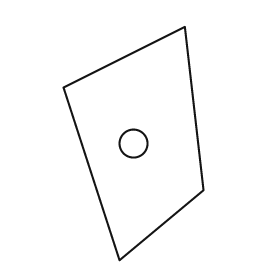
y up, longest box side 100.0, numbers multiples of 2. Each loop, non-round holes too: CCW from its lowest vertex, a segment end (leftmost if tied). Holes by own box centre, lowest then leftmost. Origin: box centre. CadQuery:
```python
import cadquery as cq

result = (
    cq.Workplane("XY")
    .moveTo(-6.0, -50.0)
    .lineTo(30.0, -20.0)
    .lineTo(22.0, 50.0)
    .lineTo(-30.0, 24.0)
    .close()
    .moveTo(0.0, 0.0)
    .circle(6.0)
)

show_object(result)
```